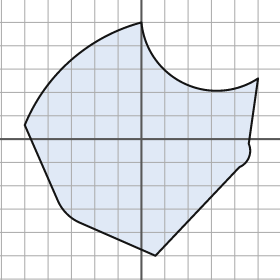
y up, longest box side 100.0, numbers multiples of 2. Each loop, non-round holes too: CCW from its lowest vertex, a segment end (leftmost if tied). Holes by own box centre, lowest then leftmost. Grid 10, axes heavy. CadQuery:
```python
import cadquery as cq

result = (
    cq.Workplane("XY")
    .moveTo(6.0, -50.0)
    .lineTo(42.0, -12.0)
    .threePointArc((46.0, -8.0), (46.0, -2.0))
    .lineTo(50.0, 26.0)
    .threePointArc((18.0, 24.0), (0.0, 50.0))
    .threePointArc((-30.0, 34.0), (-50.0, 6.0))
    .lineTo(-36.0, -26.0)
    .threePointArc((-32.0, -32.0), (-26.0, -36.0))
    .close()
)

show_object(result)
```